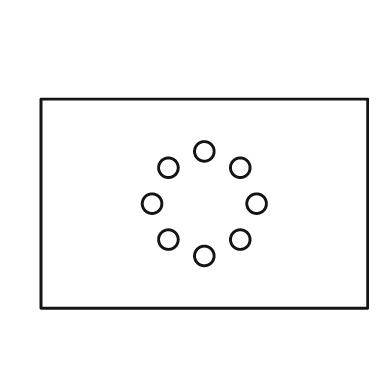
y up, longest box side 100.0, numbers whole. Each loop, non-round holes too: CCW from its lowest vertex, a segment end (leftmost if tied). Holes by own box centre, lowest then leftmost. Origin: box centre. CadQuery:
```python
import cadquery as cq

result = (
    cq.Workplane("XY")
    .moveTo(-50.0, -32.0)
    .lineTo(50.0, -32.0)
    .lineTo(50.0, 32.0)
    .lineTo(-50.0, 32.0)
    .close()
    .moveTo(0.0, -16.0)
    .circle(3.0)
    .moveTo(-11.0, -11.0)
    .circle(3.0)
    .moveTo(11.0, -11.0)
    .circle(3.0)
    .moveTo(-16.0, 0.0)
    .circle(3.0)
    .moveTo(16.0, 0.0)
    .circle(3.0)
    .moveTo(-11.0, 11.0)
    .circle(3.0)
    .moveTo(11.0, 11.0)
    .circle(3.0)
    .moveTo(0.0, 16.0)
    .circle(3.0)
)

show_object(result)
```